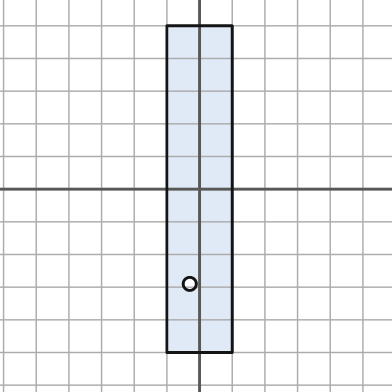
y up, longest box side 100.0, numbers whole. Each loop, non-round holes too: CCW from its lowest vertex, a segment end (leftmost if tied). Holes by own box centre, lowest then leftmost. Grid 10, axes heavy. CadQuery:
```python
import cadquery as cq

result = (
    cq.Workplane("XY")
    .moveTo(-10.0, -50.0)
    .lineTo(10.0, -50.0)
    .lineTo(10.0, 50.0)
    .lineTo(-10.0, 50.0)
    .close()
    .moveTo(-3.0, -29.0)
    .circle(2.0)
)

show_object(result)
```